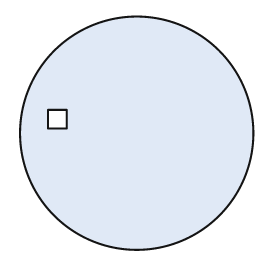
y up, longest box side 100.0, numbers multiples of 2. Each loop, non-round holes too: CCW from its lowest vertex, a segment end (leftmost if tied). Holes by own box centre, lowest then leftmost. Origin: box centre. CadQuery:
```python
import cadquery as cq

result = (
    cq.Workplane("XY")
    .moveTo(0.0, 0.0)
    .circle(50.0)
    .moveTo(-38.0, 2.0)
    .lineTo(-30.0, 2.0)
    .lineTo(-30.0, 10.0)
    .lineTo(-38.0, 10.0)
    .close()
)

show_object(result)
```